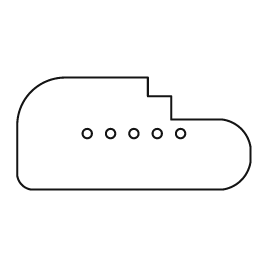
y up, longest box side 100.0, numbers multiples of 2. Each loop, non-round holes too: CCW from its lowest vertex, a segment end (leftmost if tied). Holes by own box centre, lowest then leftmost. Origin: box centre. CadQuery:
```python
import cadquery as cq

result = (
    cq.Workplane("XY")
    .moveTo(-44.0, -24.0)
    .lineTo(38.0, -24.0)
    .threePointArc((46.0, -20.0), (50.0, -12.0))
    .lineTo(50.0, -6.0)
    .threePointArc((46.0, 2.0), (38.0, 6.0))
    .lineTo(16.0, 6.0)
    .lineTo(16.0, 16.0)
    .lineTo(6.0, 16.0)
    .lineTo(6.0, 24.0)
    .lineTo(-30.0, 24.0)
    .threePointArc((-44.0, 18.0), (-50.0, 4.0))
    .lineTo(-50.0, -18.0)
    .threePointArc((-48.0, -22.0), (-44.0, -24.0))
    .close()
    .moveTo(-20.0, 0.0)
    .circle(2.0)
    .moveTo(-10.0, 0.0)
    .circle(2.0)
    .moveTo(0.0, 0.0)
    .circle(2.0)
    .moveTo(10.0, 0.0)
    .circle(2.0)
    .moveTo(20.0, 0.0)
    .circle(2.0)
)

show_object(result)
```